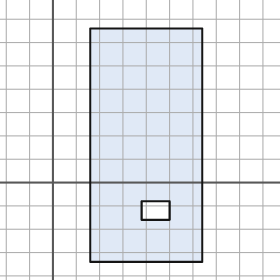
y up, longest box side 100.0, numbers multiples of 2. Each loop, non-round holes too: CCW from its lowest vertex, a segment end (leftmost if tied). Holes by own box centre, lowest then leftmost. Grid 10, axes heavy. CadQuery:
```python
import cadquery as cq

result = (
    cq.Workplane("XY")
    .moveTo(16.0, -34.0)
    .lineTo(64.0, -34.0)
    .lineTo(64.0, 66.0)
    .lineTo(16.0, 66.0)
    .close()
    .moveTo(38.0, -16.0)
    .lineTo(50.0, -16.0)
    .lineTo(50.0, -8.0)
    .lineTo(38.0, -8.0)
    .close()
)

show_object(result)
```